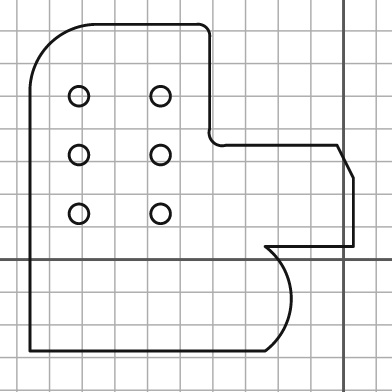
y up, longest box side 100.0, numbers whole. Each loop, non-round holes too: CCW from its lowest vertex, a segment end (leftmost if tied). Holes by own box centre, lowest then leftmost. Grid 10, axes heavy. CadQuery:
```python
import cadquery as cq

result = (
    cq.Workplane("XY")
    .moveTo(-96.0, -28.0)
    .lineTo(-24.0, -28.0)
    .threePointArc((-16.0, -12.0), (-24.0, 4.0))
    .lineTo(3.0, 4.0)
    .lineTo(3.0, 25.0)
    .lineTo(-2.0, 35.0)
    .lineTo(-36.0, 35.0)
    .threePointArc((-40.0, 36.0), (-41.0, 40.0))
    .lineTo(-41.0, 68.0)
    .threePointArc((-42.0, 71.0), (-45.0, 72.0))
    .lineTo(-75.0, 72.0)
    .threePointArc((-90.0, 66.0), (-96.0, 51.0))
    .close()
    .moveTo(-81.0, 14.0)
    .circle(3.0)
    .moveTo(-56.0, 14.0)
    .circle(3.0)
    .moveTo(-81.0, 32.0)
    .circle(3.0)
    .moveTo(-56.0, 32.0)
    .circle(3.0)
    .moveTo(-81.0, 50.0)
    .circle(3.0)
    .moveTo(-56.0, 50.0)
    .circle(3.0)
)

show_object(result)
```